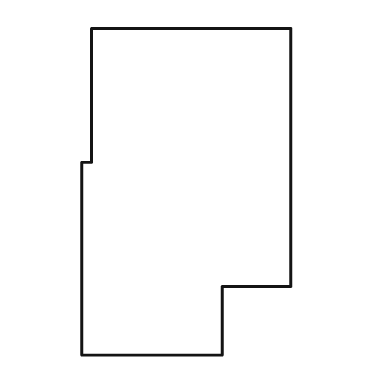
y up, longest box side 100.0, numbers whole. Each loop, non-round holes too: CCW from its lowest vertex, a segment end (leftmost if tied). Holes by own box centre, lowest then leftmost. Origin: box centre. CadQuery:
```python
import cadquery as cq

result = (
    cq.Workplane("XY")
    .moveTo(-32.0, -50.0)
    .lineTo(11.0, -50.0)
    .lineTo(11.0, -29.0)
    .lineTo(32.0, -29.0)
    .lineTo(32.0, 50.0)
    .lineTo(-29.0, 50.0)
    .lineTo(-29.0, 9.0)
    .lineTo(-32.0, 9.0)
    .close()
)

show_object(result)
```